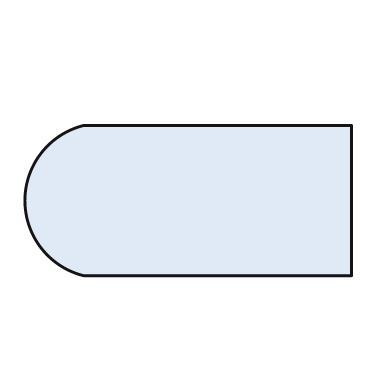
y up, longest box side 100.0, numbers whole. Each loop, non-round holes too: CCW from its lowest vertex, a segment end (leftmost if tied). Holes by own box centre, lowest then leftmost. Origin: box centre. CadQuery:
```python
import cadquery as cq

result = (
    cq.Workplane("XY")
    .moveTo(-32.0, -23.0)
    .lineTo(50.0, -23.0)
    .lineTo(50.0, 23.0)
    .lineTo(-32.0, 23.0)
    .threePointArc((-50.0, 0.0), (-32.0, -23.0))
    .close()
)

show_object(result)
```